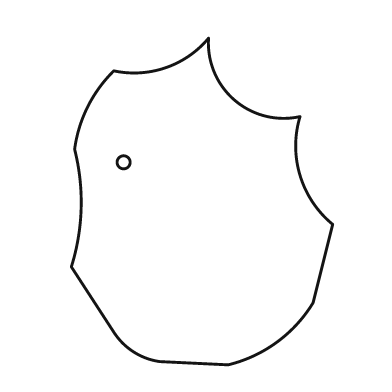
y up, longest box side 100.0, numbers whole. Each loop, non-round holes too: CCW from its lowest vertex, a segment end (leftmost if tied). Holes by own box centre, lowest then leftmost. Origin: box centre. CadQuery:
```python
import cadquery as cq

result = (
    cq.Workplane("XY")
    .moveTo(8.0, -50.0)
    .threePointArc((23.0, -43.0), (34.0, -31.0))
    .lineTo(40.0, -7.0)
    .threePointArc((30.0, 8.0), (30.0, 26.0))
    .threePointArc((10.0, 31.0), (2.0, 50.0))
    .threePointArc((-11.0, 41.0), (-27.0, 40.0))
    .threePointArc((-35.0, 29.0), (-39.0, 16.0))
    .threePointArc((-37.0, -2.0), (-40.0, -20.0))
    .lineTo(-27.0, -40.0)
    .threePointArc((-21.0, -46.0), (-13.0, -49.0))
    .close()
    .moveTo(-24.0, 12.0)
    .circle(2.0)
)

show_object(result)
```